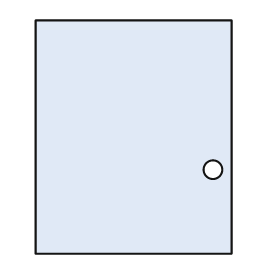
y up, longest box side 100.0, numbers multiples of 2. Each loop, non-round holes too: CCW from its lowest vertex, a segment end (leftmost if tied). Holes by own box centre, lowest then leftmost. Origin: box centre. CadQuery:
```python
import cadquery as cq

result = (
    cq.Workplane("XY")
    .moveTo(-42.0, -50.0)
    .lineTo(42.0, -50.0)
    .lineTo(42.0, 50.0)
    .lineTo(-42.0, 50.0)
    .close()
    .moveTo(34.0, -14.0)
    .circle(4.0)
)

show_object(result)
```